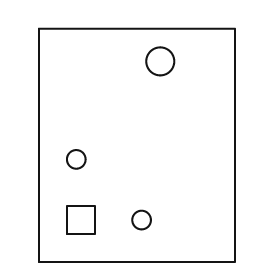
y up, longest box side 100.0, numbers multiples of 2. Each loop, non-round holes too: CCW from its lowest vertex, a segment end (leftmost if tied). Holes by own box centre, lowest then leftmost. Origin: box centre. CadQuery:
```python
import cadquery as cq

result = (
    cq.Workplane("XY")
    .moveTo(-42.0, -50.0)
    .lineTo(42.0, -50.0)
    .lineTo(42.0, 50.0)
    .lineTo(-42.0, 50.0)
    .close()
    .moveTo(-30.0, -38.0)
    .lineTo(-18.0, -38.0)
    .lineTo(-18.0, -26.0)
    .lineTo(-30.0, -26.0)
    .close()
    .moveTo(2.0, -32.0)
    .circle(4.0)
    .moveTo(-26.0, -6.0)
    .circle(4.0)
    .moveTo(10.0, 36.0)
    .circle(6.0)
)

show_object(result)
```